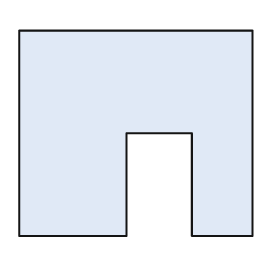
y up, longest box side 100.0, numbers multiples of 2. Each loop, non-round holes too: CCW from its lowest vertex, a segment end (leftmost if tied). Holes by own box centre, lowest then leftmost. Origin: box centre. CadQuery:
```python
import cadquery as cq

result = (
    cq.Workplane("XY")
    .moveTo(-50.0, -44.0)
    .lineTo(-4.0, -44.0)
    .lineTo(-4.0, 0.0)
    .lineTo(24.0, 0.0)
    .lineTo(24.0, -44.0)
    .lineTo(50.0, -44.0)
    .lineTo(50.0, 44.0)
    .lineTo(-50.0, 44.0)
    .close()
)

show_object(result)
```